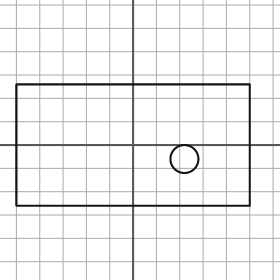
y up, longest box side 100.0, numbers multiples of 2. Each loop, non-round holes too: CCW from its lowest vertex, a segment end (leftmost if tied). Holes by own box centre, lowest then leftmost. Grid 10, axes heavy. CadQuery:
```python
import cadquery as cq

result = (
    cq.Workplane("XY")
    .moveTo(-50.0, -26.0)
    .lineTo(50.0, -26.0)
    .lineTo(50.0, 26.0)
    .lineTo(-50.0, 26.0)
    .close()
    .moveTo(22.0, -6.0)
    .circle(6.0)
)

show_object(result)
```